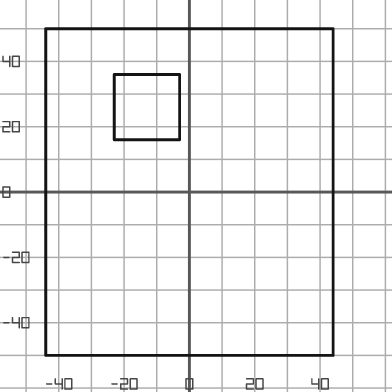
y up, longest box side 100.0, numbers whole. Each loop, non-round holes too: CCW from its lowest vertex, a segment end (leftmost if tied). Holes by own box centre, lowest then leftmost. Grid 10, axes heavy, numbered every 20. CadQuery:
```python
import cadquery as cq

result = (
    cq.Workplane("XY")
    .moveTo(-44.0, -50.0)
    .lineTo(44.0, -50.0)
    .lineTo(44.0, 50.0)
    .lineTo(-44.0, 50.0)
    .close()
    .moveTo(-23.0, 16.0)
    .lineTo(-3.0, 16.0)
    .lineTo(-3.0, 36.0)
    .lineTo(-23.0, 36.0)
    .close()
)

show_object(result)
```